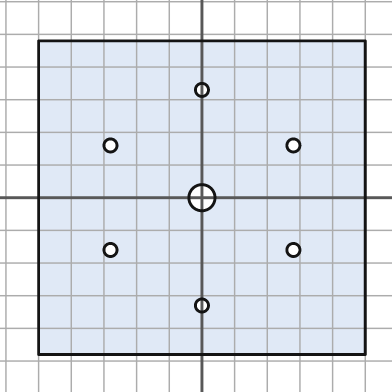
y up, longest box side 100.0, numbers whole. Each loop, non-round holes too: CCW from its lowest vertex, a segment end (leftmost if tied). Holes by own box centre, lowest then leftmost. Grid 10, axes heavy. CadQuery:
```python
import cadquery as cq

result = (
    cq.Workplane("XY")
    .moveTo(-50.0, -48.0)
    .lineTo(50.0, -48.0)
    .lineTo(50.0, 48.0)
    .lineTo(-50.0, 48.0)
    .close()
    .moveTo(0.0, -33.0)
    .circle(2.0)
    .moveTo(-28.0, -16.0)
    .circle(2.0)
    .moveTo(28.0, -16.0)
    .circle(2.0)
    .moveTo(0.0, 0.0)
    .circle(4.0)
    .moveTo(-28.0, 16.0)
    .circle(2.0)
    .moveTo(28.0, 16.0)
    .circle(2.0)
    .moveTo(0.0, 33.0)
    .circle(2.0)
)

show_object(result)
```